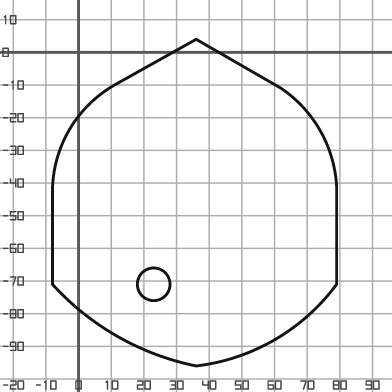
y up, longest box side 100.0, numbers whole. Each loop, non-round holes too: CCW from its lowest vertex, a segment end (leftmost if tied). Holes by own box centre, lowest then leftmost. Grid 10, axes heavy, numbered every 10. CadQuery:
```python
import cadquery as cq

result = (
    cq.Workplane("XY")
    .moveTo(36.0, -96.0)
    .threePointArc((60.0, -88.0), (79.0, -71.0))
    .lineTo(79.0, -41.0)
    .threePointArc((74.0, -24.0), (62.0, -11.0))
    .lineTo(36.0, 4.0)
    .lineTo(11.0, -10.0)
    .threePointArc((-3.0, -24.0), (-8.0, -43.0))
    .lineTo(-8.0, -71.0)
    .threePointArc((12.0, -87.0), (36.0, -96.0))
    .close()
    .moveTo(23.0, -71.0)
    .circle(5.0)
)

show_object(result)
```